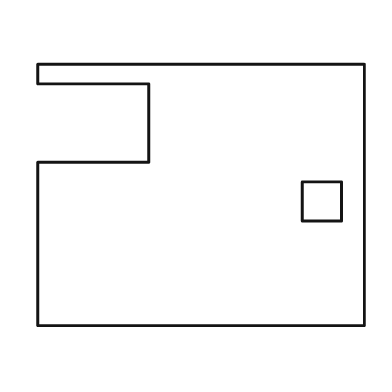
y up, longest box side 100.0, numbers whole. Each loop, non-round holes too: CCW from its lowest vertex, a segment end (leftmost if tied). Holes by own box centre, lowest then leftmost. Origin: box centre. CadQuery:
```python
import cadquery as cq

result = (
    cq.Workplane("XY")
    .moveTo(-50.0, -40.0)
    .lineTo(50.0, -40.0)
    .lineTo(50.0, 40.0)
    .lineTo(-50.0, 40.0)
    .lineTo(-50.0, 34.0)
    .lineTo(-16.0, 34.0)
    .lineTo(-16.0, 10.0)
    .lineTo(-50.0, 10.0)
    .close()
    .moveTo(31.0, -8.0)
    .lineTo(43.0, -8.0)
    .lineTo(43.0, 4.0)
    .lineTo(31.0, 4.0)
    .close()
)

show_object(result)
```